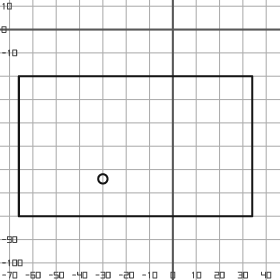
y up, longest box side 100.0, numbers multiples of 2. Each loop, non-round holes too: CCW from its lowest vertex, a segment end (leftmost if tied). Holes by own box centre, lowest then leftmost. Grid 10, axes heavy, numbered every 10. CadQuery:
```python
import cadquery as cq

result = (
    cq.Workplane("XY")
    .moveTo(-66.0, -80.0)
    .lineTo(34.0, -80.0)
    .lineTo(34.0, -20.0)
    .lineTo(-66.0, -20.0)
    .close()
    .moveTo(-30.0, -64.0)
    .circle(2.0)
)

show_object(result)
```